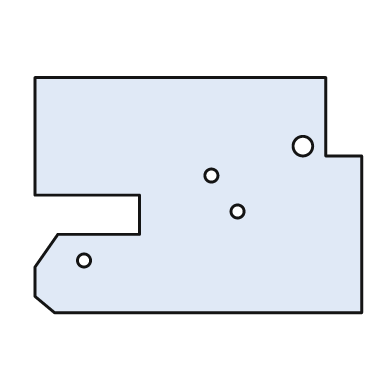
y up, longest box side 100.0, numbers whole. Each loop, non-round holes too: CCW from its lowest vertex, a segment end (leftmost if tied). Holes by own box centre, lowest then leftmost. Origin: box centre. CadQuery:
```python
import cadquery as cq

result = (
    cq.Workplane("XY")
    .moveTo(-44.0, -36.0)
    .lineTo(50.0, -36.0)
    .lineTo(50.0, 12.0)
    .lineTo(39.0, 12.0)
    .lineTo(39.0, 36.0)
    .lineTo(-50.0, 36.0)
    .lineTo(-50.0, 0.0)
    .lineTo(-18.0, 0.0)
    .lineTo(-18.0, -12.0)
    .lineTo(-43.0, -12.0)
    .lineTo(-50.0, -22.0)
    .lineTo(-50.0, -31.0)
    .close()
    .moveTo(-35.0, -20.0)
    .circle(2.0)
    .moveTo(12.0, -5.0)
    .circle(2.0)
    .moveTo(4.0, 6.0)
    .circle(2.0)
    .moveTo(32.0, 15.0)
    .circle(3.0)
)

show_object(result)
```